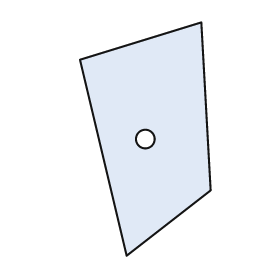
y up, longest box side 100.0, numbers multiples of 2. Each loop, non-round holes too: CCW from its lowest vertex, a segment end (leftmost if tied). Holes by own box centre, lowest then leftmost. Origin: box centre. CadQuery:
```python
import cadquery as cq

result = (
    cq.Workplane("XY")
    .moveTo(-8.0, -50.0)
    .lineTo(28.0, -22.0)
    .lineTo(24.0, 50.0)
    .lineTo(-28.0, 34.0)
    .close()
    .moveTo(0.0, 0.0)
    .circle(4.0)
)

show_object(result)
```